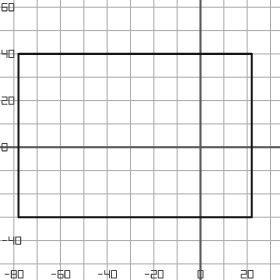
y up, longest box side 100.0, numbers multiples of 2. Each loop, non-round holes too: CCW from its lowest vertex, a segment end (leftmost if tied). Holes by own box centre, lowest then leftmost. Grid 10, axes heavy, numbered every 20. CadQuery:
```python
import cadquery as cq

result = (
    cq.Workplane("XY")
    .moveTo(-78.0, -30.0)
    .lineTo(22.0, -30.0)
    .lineTo(22.0, 40.0)
    .lineTo(-78.0, 40.0)
    .close()
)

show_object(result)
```